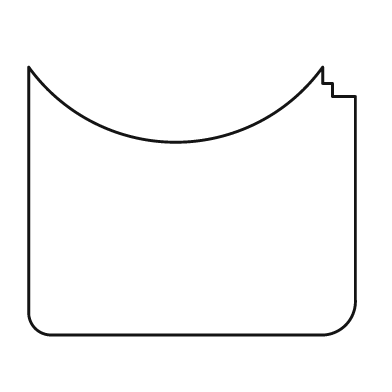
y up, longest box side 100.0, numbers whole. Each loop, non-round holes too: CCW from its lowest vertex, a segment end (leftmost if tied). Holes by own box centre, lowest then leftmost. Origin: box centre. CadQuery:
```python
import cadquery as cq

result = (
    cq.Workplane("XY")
    .moveTo(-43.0, -41.0)
    .lineTo(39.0, -41.0)
    .threePointArc((47.0, -38.0), (50.0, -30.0))
    .lineTo(50.0, 32.0)
    .lineTo(43.0, 32.0)
    .lineTo(43.0, 36.0)
    .lineTo(40.0, 36.0)
    .lineTo(40.0, 41.0)
    .threePointArc((-5.0, 18.0), (-50.0, 41.0))
    .lineTo(-50.0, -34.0)
    .threePointArc((-48.0, -39.0), (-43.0, -41.0))
    .close()
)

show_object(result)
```